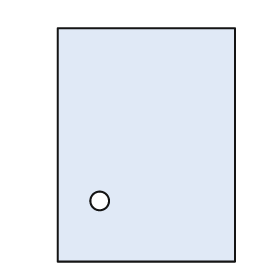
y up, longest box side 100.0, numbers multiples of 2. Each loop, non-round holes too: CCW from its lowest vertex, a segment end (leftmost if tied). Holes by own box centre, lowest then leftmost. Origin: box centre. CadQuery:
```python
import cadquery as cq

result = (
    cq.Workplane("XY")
    .moveTo(-38.0, -50.0)
    .lineTo(38.0, -50.0)
    .lineTo(38.0, 50.0)
    .lineTo(-38.0, 50.0)
    .close()
    .moveTo(-20.0, -24.0)
    .circle(4.0)
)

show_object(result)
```